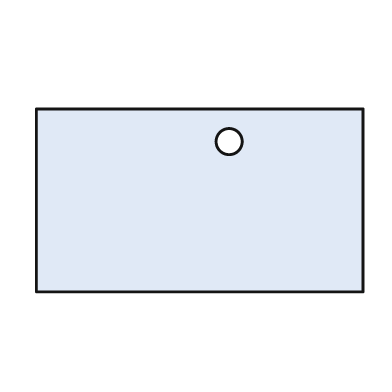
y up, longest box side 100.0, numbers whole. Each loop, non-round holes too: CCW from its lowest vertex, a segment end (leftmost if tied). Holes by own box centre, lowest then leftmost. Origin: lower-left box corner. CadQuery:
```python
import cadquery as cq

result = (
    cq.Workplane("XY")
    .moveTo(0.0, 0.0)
    .lineTo(100.0, 0.0)
    .lineTo(100.0, 56.0)
    .lineTo(0.0, 56.0)
    .close()
    .moveTo(59.0, 46.0)
    .circle(4.0)
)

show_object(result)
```